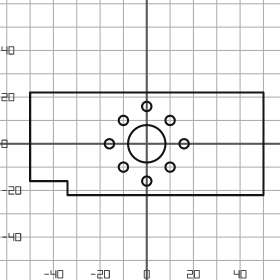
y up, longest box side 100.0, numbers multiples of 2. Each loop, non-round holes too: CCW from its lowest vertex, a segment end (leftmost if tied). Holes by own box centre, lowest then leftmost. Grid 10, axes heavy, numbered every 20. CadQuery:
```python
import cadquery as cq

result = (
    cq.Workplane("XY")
    .moveTo(-34.0, -22.0)
    .lineTo(50.0, -22.0)
    .lineTo(50.0, 22.0)
    .lineTo(-50.0, 22.0)
    .lineTo(-50.0, -16.0)
    .lineTo(-34.0, -16.0)
    .close()
    .moveTo(0.0, -16.0)
    .circle(2.0)
    .moveTo(-10.0, -10.0)
    .circle(2.0)
    .moveTo(10.0, -10.0)
    .circle(2.0)
    .moveTo(-16.0, 0.0)
    .circle(2.0)
    .moveTo(0.0, 0.0)
    .circle(8.0)
    .moveTo(16.0, 0.0)
    .circle(2.0)
    .moveTo(-10.0, 10.0)
    .circle(2.0)
    .moveTo(10.0, 10.0)
    .circle(2.0)
    .moveTo(0.0, 16.0)
    .circle(2.0)
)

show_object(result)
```